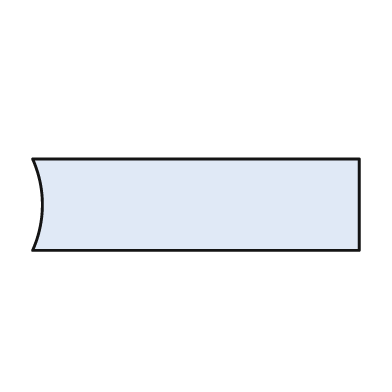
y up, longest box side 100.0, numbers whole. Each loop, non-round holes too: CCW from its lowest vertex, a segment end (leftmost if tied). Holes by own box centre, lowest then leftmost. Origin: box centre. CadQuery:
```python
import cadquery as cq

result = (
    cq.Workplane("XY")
    .moveTo(-50.0, -14.0)
    .lineTo(50.0, -14.0)
    .lineTo(50.0, 14.0)
    .lineTo(-50.0, 14.0)
    .threePointArc((-47.0, 0.0), (-50.0, -14.0))
    .close()
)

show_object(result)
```